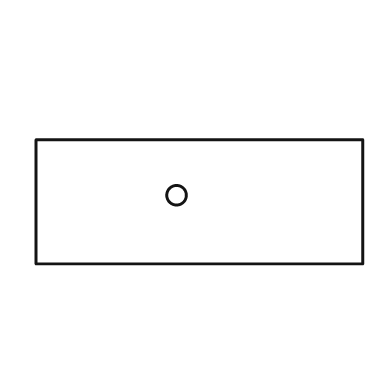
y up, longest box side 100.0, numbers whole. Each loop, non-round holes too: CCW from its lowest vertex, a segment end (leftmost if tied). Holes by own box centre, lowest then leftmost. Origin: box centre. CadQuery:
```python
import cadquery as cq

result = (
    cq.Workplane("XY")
    .moveTo(-50.0, -19.0)
    .lineTo(50.0, -19.0)
    .lineTo(50.0, 19.0)
    .lineTo(-50.0, 19.0)
    .close()
    .moveTo(-7.0, 2.0)
    .circle(3.0)
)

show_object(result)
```